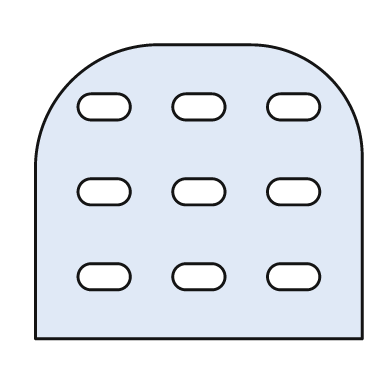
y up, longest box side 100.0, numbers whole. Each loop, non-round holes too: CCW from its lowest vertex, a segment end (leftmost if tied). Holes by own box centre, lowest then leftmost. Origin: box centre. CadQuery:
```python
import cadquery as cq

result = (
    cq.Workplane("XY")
    .moveTo(-50.0, -45.0)
    .lineTo(50.0, -45.0)
    .lineTo(50.0, 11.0)
    .threePointArc((40.0, 35.0), (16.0, 45.0))
    .lineTo(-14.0, 45.0)
    .threePointArc((-39.0, 34.0), (-50.0, 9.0))
    .close()
    .moveTo(-33.0, -30.0)
    .lineTo(-25.0, -30.0)
    .threePointArc((-21.0, -26.0), (-25.0, -22.0))
    .lineTo(-33.0, -22.0)
    .threePointArc((-37.0, -26.0), (-33.0, -30.0))
    .close()
    .moveTo(-4.0, -30.0)
    .lineTo(4.0, -30.0)
    .threePointArc((8.0, -26.0), (4.0, -22.0))
    .lineTo(-4.0, -22.0)
    .threePointArc((-8.0, -26.0), (-4.0, -30.0))
    .close()
    .moveTo(25.0, -30.0)
    .lineTo(33.0, -30.0)
    .threePointArc((37.0, -26.0), (33.0, -22.0))
    .lineTo(25.0, -22.0)
    .threePointArc((21.0, -26.0), (25.0, -30.0))
    .close()
    .moveTo(-33.0, -4.0)
    .lineTo(-25.0, -4.0)
    .threePointArc((-21.0, 0.0), (-25.0, 4.0))
    .lineTo(-33.0, 4.0)
    .threePointArc((-37.0, 0.0), (-33.0, -4.0))
    .close()
    .moveTo(-4.0, -4.0)
    .lineTo(4.0, -4.0)
    .threePointArc((8.0, 0.0), (4.0, 4.0))
    .lineTo(-4.0, 4.0)
    .threePointArc((-8.0, 0.0), (-4.0, -4.0))
    .close()
    .moveTo(25.0, -4.0)
    .lineTo(33.0, -4.0)
    .threePointArc((37.0, 0.0), (33.0, 4.0))
    .lineTo(25.0, 4.0)
    .threePointArc((21.0, 0.0), (25.0, -4.0))
    .close()
    .moveTo(-33.0, 22.0)
    .lineTo(-25.0, 22.0)
    .threePointArc((-21.0, 26.0), (-25.0, 30.0))
    .lineTo(-33.0, 30.0)
    .threePointArc((-37.0, 26.0), (-33.0, 22.0))
    .close()
    .moveTo(-4.0, 22.0)
    .lineTo(4.0, 22.0)
    .threePointArc((8.0, 26.0), (4.0, 30.0))
    .lineTo(-4.0, 30.0)
    .threePointArc((-8.0, 26.0), (-4.0, 22.0))
    .close()
    .moveTo(25.0, 22.0)
    .lineTo(33.0, 22.0)
    .threePointArc((37.0, 26.0), (33.0, 30.0))
    .lineTo(25.0, 30.0)
    .threePointArc((21.0, 26.0), (25.0, 22.0))
    .close()
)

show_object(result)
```